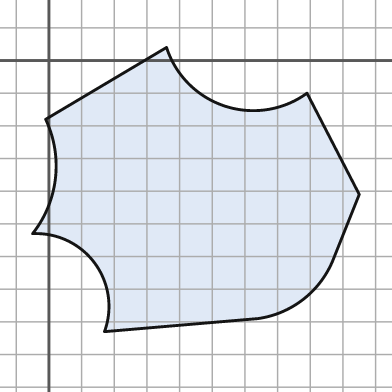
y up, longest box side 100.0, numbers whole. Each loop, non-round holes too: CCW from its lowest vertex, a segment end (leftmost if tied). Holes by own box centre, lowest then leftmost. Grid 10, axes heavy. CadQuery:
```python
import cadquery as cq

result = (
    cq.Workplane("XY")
    .moveTo(17.0, -83.0)
    .lineTo(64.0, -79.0)
    .threePointArc((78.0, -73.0), (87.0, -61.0))
    .lineTo(95.0, -41.0)
    .lineTo(79.0, -10.0)
    .threePointArc((54.0, -14.0), (36.0, 4.0))
    .lineTo(-1.0, -18.0)
    .threePointArc((2.0, -36.0), (-5.0, -53.0))
    .threePointArc((14.0, -62.0), (17.0, -83.0))
    .close()
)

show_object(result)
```